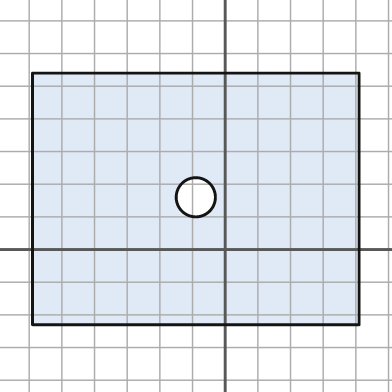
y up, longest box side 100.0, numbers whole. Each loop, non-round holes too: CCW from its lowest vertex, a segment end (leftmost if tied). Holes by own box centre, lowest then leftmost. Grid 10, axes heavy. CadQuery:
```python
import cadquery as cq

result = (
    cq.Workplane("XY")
    .moveTo(-59.0, -23.0)
    .lineTo(41.0, -23.0)
    .lineTo(41.0, 54.0)
    .lineTo(-59.0, 54.0)
    .close()
    .moveTo(-9.0, 16.0)
    .circle(6.0)
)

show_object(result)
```